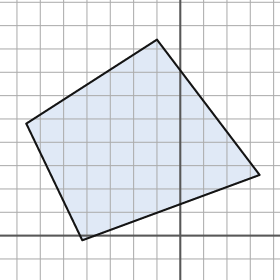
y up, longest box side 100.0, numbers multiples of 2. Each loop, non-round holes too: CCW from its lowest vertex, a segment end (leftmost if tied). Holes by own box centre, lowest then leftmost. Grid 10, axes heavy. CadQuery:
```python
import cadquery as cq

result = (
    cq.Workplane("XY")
    .moveTo(-42.0, -2.0)
    .lineTo(34.0, 26.0)
    .lineTo(-10.0, 84.0)
    .lineTo(-66.0, 48.0)
    .close()
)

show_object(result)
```